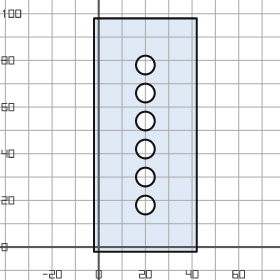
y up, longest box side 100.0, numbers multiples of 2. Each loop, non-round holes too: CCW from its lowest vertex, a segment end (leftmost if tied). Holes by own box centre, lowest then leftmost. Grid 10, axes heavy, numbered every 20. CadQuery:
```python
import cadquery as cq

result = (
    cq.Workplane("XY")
    .moveTo(-2.0, -2.0)
    .lineTo(42.0, -2.0)
    .lineTo(42.0, 98.0)
    .lineTo(-2.0, 98.0)
    .close()
    .moveTo(20.0, 18.0)
    .circle(4.0)
    .moveTo(20.0, 30.0)
    .circle(4.0)
    .moveTo(20.0, 42.0)
    .circle(4.0)
    .moveTo(20.0, 54.0)
    .circle(4.0)
    .moveTo(20.0, 66.0)
    .circle(4.0)
    .moveTo(20.0, 78.0)
    .circle(4.0)
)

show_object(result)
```